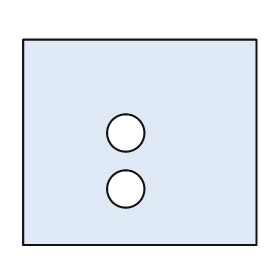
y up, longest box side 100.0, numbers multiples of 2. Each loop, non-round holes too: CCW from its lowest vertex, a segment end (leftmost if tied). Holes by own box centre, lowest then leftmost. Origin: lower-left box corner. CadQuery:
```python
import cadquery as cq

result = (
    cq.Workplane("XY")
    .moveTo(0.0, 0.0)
    .lineTo(100.0, 0.0)
    .lineTo(100.0, 88.0)
    .lineTo(0.0, 88.0)
    .close()
    .moveTo(44.0, 24.0)
    .circle(8.0)
    .moveTo(44.0, 48.0)
    .circle(8.0)
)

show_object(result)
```